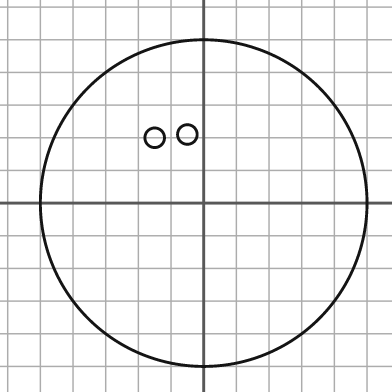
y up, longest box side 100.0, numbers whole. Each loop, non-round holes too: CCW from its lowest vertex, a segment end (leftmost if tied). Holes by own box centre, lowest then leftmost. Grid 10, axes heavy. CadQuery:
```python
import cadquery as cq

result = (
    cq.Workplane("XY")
    .moveTo(0.0, 0.0)
    .circle(50.0)
    .moveTo(-15.0, 20.0)
    .circle(3.0)
    .moveTo(-5.0, 21.0)
    .circle(3.0)
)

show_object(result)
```